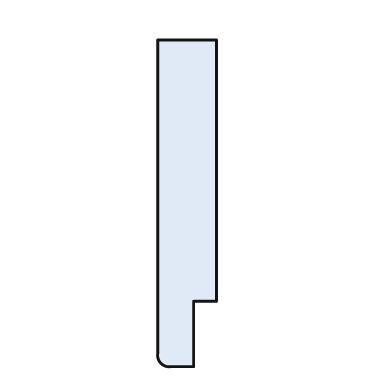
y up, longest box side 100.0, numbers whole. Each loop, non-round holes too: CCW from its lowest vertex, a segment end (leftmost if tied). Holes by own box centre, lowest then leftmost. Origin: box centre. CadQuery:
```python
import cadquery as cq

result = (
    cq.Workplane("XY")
    .moveTo(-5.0, -50.0)
    .lineTo(2.0, -50.0)
    .lineTo(2.0, -30.0)
    .lineTo(9.0, -30.0)
    .lineTo(9.0, 50.0)
    .lineTo(-9.0, 50.0)
    .lineTo(-9.0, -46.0)
    .threePointArc((-8.0, -49.0), (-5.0, -50.0))
    .close()
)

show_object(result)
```